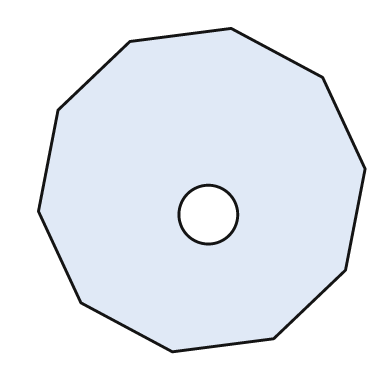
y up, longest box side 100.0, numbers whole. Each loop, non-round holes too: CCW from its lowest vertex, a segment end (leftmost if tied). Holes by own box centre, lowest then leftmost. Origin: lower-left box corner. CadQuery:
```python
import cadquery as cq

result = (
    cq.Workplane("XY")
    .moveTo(41.0, 0.0)
    .lineTo(72.0, 4.0)
    .lineTo(94.0, 25.0)
    .lineTo(100.0, 56.0)
    .lineTo(87.0, 84.0)
    .lineTo(59.0, 99.0)
    .lineTo(28.0, 95.0)
    .lineTo(6.0, 74.0)
    .lineTo(0.0, 43.0)
    .lineTo(13.0, 15.0)
    .close()
    .moveTo(52.0, 42.0)
    .circle(9.0)
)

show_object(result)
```